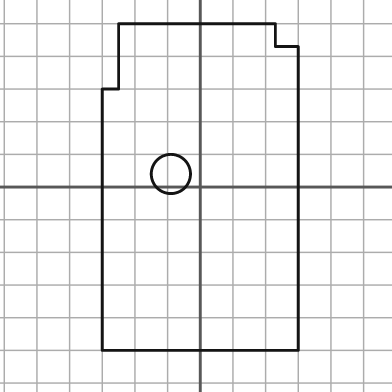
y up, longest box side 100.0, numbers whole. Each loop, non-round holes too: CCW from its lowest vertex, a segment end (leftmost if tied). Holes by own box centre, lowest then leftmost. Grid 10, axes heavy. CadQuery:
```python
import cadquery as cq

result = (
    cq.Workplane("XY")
    .moveTo(-30.0, -50.0)
    .lineTo(30.0, -50.0)
    .lineTo(30.0, 43.0)
    .lineTo(23.0, 43.0)
    .lineTo(23.0, 50.0)
    .lineTo(-25.0, 50.0)
    .lineTo(-25.0, 30.0)
    .lineTo(-30.0, 30.0)
    .close()
    .moveTo(-9.0, 4.0)
    .circle(6.0)
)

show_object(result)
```